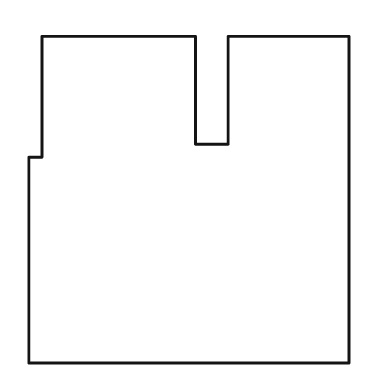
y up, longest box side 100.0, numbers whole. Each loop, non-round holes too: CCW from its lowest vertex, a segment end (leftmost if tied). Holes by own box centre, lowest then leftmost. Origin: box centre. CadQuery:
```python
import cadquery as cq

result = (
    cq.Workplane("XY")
    .moveTo(-49.0, -50.0)
    .lineTo(49.0, -50.0)
    .lineTo(49.0, 50.0)
    .lineTo(12.0, 50.0)
    .lineTo(12.0, 17.0)
    .lineTo(2.0, 17.0)
    .lineTo(2.0, 50.0)
    .lineTo(-45.0, 50.0)
    .lineTo(-45.0, 13.0)
    .lineTo(-49.0, 13.0)
    .close()
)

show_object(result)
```